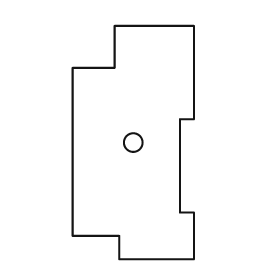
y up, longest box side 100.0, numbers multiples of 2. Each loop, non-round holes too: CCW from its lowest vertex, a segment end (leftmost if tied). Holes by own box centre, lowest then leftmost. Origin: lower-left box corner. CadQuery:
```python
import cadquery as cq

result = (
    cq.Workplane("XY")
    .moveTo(20.0, 0.0)
    .lineTo(52.0, 0.0)
    .lineTo(52.0, 20.0)
    .lineTo(46.0, 20.0)
    .lineTo(46.0, 60.0)
    .lineTo(52.0, 60.0)
    .lineTo(52.0, 100.0)
    .lineTo(18.0, 100.0)
    .lineTo(18.0, 82.0)
    .lineTo(0.0, 82.0)
    .lineTo(0.0, 10.0)
    .lineTo(20.0, 10.0)
    .close()
    .moveTo(26.0, 50.0)
    .circle(4.0)
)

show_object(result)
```